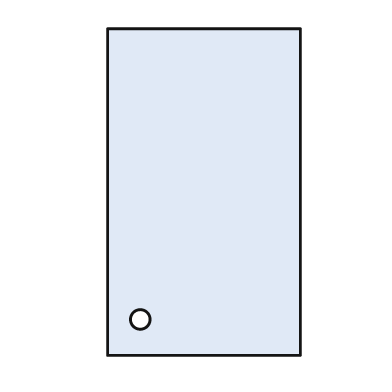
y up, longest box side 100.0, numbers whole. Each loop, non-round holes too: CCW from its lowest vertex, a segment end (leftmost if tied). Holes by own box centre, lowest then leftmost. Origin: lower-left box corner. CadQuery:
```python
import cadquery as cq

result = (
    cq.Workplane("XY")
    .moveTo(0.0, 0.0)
    .lineTo(59.0, 0.0)
    .lineTo(59.0, 100.0)
    .lineTo(0.0, 100.0)
    .close()
    .moveTo(10.0, 11.0)
    .circle(3.0)
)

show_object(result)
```